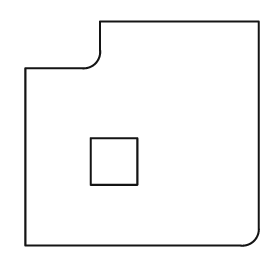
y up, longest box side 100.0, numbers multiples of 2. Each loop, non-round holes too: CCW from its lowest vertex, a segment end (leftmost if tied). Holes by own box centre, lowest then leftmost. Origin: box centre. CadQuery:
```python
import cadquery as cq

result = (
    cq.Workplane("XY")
    .moveTo(-50.0, -48.0)
    .lineTo(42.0, -48.0)
    .threePointArc((48.0, -46.0), (50.0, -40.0))
    .lineTo(50.0, 48.0)
    .lineTo(-18.0, 48.0)
    .lineTo(-18.0, 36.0)
    .threePointArc((-20.0, 30.0), (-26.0, 28.0))
    .lineTo(-50.0, 28.0)
    .close()
    .moveTo(-22.0, -22.0)
    .lineTo(-2.0, -22.0)
    .lineTo(-2.0, -2.0)
    .lineTo(-22.0, -2.0)
    .close()
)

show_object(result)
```